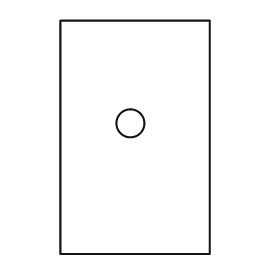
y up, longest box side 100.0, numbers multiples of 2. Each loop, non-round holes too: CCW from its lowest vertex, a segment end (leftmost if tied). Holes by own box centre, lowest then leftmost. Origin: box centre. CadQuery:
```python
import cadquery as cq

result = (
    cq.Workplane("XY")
    .moveTo(-32.0, -50.0)
    .lineTo(32.0, -50.0)
    .lineTo(32.0, 50.0)
    .lineTo(-32.0, 50.0)
    .close()
    .moveTo(-2.0, 6.0)
    .circle(6.0)
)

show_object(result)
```